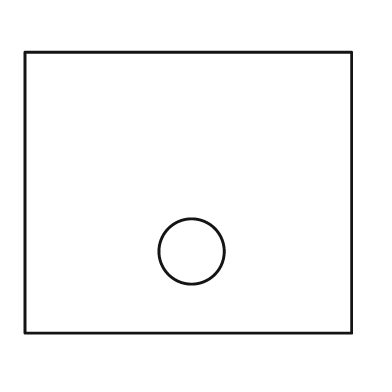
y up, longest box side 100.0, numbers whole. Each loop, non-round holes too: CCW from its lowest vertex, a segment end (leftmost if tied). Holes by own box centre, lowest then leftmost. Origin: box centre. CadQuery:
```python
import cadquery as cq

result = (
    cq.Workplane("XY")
    .moveTo(-50.0, -43.0)
    .lineTo(50.0, -43.0)
    .lineTo(50.0, 43.0)
    .lineTo(-50.0, 43.0)
    .close()
    .moveTo(1.0, -18.0)
    .circle(10.0)
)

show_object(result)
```